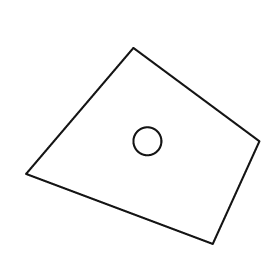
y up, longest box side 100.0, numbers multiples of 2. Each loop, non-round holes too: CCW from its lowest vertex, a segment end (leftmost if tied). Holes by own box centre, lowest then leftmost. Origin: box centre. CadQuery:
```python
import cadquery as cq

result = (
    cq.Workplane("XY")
    .moveTo(30.0, -42.0)
    .lineTo(50.0, 2.0)
    .lineTo(-4.0, 42.0)
    .lineTo(-50.0, -12.0)
    .close()
    .moveTo(2.0, 2.0)
    .circle(6.0)
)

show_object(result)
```